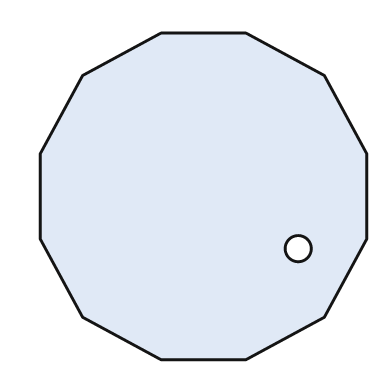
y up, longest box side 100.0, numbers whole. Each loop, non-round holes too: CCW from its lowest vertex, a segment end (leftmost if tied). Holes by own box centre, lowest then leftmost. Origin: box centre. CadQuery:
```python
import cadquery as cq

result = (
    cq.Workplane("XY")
    .moveTo(-13.0, -50.0)
    .lineTo(13.0, -50.0)
    .lineTo(37.0, -37.0)
    .lineTo(50.0, -13.0)
    .lineTo(50.0, 13.0)
    .lineTo(37.0, 37.0)
    .lineTo(13.0, 50.0)
    .lineTo(-13.0, 50.0)
    .lineTo(-37.0, 37.0)
    .lineTo(-50.0, 13.0)
    .lineTo(-50.0, -13.0)
    .lineTo(-37.0, -37.0)
    .close()
    .moveTo(29.0, -16.0)
    .circle(4.0)
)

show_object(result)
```